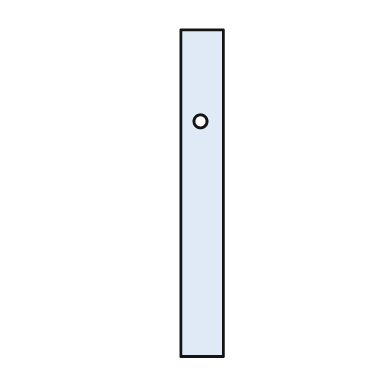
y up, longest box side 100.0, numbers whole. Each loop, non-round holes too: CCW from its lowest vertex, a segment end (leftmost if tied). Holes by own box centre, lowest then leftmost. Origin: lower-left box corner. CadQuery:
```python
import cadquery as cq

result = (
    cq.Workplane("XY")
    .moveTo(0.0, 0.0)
    .lineTo(13.0, 0.0)
    .lineTo(13.0, 100.0)
    .lineTo(0.0, 100.0)
    .close()
    .moveTo(6.0, 72.0)
    .circle(2.0)
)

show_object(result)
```